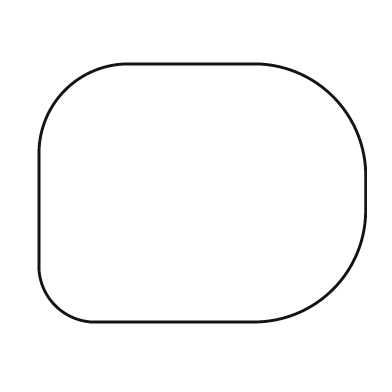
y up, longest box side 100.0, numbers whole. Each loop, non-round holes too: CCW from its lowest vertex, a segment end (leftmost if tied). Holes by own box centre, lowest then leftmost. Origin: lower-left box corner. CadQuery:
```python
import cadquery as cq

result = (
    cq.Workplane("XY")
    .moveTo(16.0, 0.0)
    .lineTo(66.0, 0.0)
    .threePointArc((90.0, 10.0), (100.0, 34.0))
    .lineTo(100.0, 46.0)
    .threePointArc((90.0, 69.0), (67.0, 79.0))
    .lineTo(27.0, 79.0)
    .threePointArc((8.0, 71.0), (0.0, 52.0))
    .lineTo(0.0, 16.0)
    .threePointArc((5.0, 5.0), (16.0, 0.0))
    .close()
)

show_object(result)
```